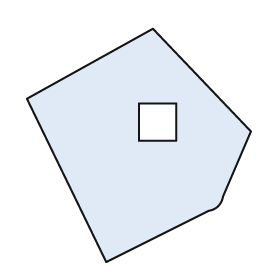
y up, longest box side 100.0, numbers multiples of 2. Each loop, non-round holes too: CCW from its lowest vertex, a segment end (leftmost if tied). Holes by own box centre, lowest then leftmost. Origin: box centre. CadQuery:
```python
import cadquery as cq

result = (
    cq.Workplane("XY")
    .moveTo(-14.0, -50.0)
    .lineTo(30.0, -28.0)
    .threePointArc((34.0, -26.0), (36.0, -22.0))
    .lineTo(48.0, 6.0)
    .lineTo(6.0, 50.0)
    .lineTo(-48.0, 20.0)
    .close()
    .moveTo(0.0, 2.0)
    .lineTo(16.0, 2.0)
    .lineTo(16.0, 18.0)
    .lineTo(0.0, 18.0)
    .close()
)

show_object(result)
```